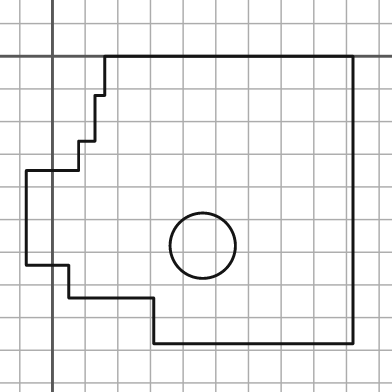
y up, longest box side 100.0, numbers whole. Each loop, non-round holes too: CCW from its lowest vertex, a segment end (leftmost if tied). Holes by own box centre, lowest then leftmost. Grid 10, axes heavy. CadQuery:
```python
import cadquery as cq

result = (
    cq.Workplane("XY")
    .moveTo(31.0, -88.0)
    .lineTo(92.0, -88.0)
    .lineTo(92.0, 0.0)
    .lineTo(16.0, 0.0)
    .lineTo(16.0, -12.0)
    .lineTo(13.0, -12.0)
    .lineTo(13.0, -26.0)
    .lineTo(8.0, -26.0)
    .lineTo(8.0, -35.0)
    .lineTo(-8.0, -35.0)
    .lineTo(-8.0, -64.0)
    .lineTo(5.0, -64.0)
    .lineTo(5.0, -74.0)
    .lineTo(31.0, -74.0)
    .close()
    .moveTo(46.0, -58.0)
    .circle(10.0)
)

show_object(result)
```